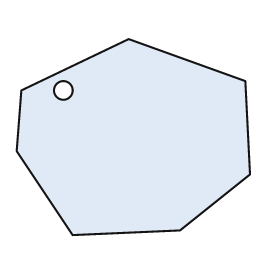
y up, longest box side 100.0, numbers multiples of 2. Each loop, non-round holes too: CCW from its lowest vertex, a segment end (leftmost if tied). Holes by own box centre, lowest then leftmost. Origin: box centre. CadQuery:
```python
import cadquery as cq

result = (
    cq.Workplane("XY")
    .moveTo(-26.0, -42.0)
    .lineTo(20.0, -40.0)
    .lineTo(50.0, -16.0)
    .lineTo(48.0, 24.0)
    .lineTo(-2.0, 42.0)
    .lineTo(-48.0, 20.0)
    .lineTo(-50.0, -6.0)
    .close()
    .moveTo(-30.0, 20.0)
    .circle(4.0)
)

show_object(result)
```